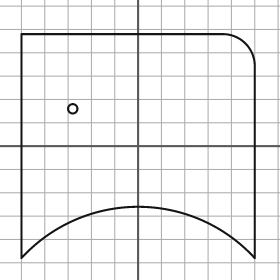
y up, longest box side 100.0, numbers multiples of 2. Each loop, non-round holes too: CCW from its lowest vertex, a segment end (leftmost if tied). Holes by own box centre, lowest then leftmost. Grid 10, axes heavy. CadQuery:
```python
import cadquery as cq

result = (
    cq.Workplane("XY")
    .moveTo(-50.0, -48.0)
    .threePointArc((0.0, -26.0), (50.0, -48.0))
    .lineTo(50.0, 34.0)
    .threePointArc((46.0, 44.0), (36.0, 48.0))
    .lineTo(-50.0, 48.0)
    .close()
    .moveTo(-28.0, 16.0)
    .circle(2.0)
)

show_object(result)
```